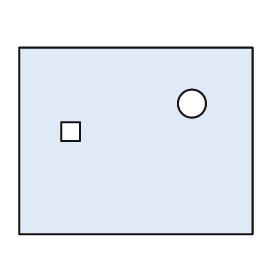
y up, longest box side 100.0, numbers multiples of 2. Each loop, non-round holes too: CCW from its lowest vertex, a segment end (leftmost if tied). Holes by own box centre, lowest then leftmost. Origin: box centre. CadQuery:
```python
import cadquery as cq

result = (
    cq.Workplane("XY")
    .moveTo(-50.0, -40.0)
    .lineTo(50.0, -40.0)
    .lineTo(50.0, 40.0)
    .lineTo(-50.0, 40.0)
    .close()
    .moveTo(-32.0, 0.0)
    .lineTo(-24.0, 0.0)
    .lineTo(-24.0, 8.0)
    .lineTo(-32.0, 8.0)
    .close()
    .moveTo(24.0, 16.0)
    .circle(6.0)
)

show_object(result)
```